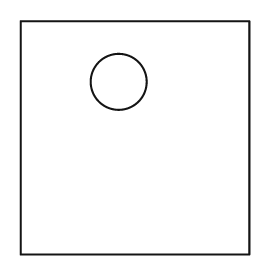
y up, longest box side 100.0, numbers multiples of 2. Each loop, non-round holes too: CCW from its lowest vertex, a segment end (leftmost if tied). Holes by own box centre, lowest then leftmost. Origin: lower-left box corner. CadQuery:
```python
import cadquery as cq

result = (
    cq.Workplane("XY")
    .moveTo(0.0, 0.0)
    .lineTo(98.0, 0.0)
    .lineTo(98.0, 100.0)
    .lineTo(0.0, 100.0)
    .close()
    .moveTo(42.0, 74.0)
    .circle(12.0)
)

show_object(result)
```